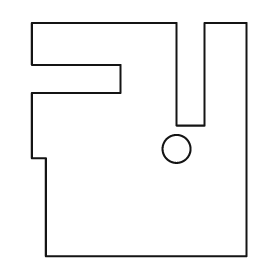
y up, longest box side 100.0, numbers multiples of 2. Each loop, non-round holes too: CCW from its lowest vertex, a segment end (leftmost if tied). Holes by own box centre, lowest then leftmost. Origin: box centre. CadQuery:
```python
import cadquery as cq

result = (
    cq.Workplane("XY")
    .moveTo(-40.0, -50.0)
    .lineTo(46.0, -50.0)
    .lineTo(46.0, 50.0)
    .lineTo(28.0, 50.0)
    .lineTo(28.0, 6.0)
    .lineTo(16.0, 6.0)
    .lineTo(16.0, 50.0)
    .lineTo(-46.0, 50.0)
    .lineTo(-46.0, 32.0)
    .lineTo(-8.0, 32.0)
    .lineTo(-8.0, 20.0)
    .lineTo(-46.0, 20.0)
    .lineTo(-46.0, -8.0)
    .lineTo(-40.0, -8.0)
    .close()
    .moveTo(16.0, -4.0)
    .circle(6.0)
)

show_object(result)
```